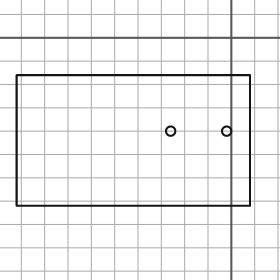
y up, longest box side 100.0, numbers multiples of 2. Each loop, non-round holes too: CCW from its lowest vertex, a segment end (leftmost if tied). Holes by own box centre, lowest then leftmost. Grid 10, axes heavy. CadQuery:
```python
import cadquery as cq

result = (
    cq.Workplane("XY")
    .moveTo(-92.0, -72.0)
    .lineTo(8.0, -72.0)
    .lineTo(8.0, -16.0)
    .lineTo(-92.0, -16.0)
    .close()
    .moveTo(-26.0, -40.0)
    .circle(2.0)
    .moveTo(-2.0, -40.0)
    .circle(2.0)
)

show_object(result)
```